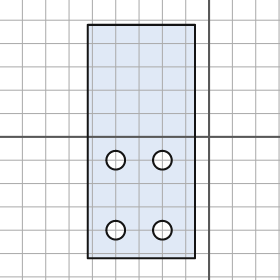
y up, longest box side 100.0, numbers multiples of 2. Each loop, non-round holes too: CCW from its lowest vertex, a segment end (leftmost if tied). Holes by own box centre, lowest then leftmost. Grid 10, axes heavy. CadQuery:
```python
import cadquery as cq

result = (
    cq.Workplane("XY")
    .moveTo(-52.0, -52.0)
    .lineTo(-6.0, -52.0)
    .lineTo(-6.0, 48.0)
    .lineTo(-52.0, 48.0)
    .close()
    .moveTo(-40.0, -40.0)
    .circle(4.0)
    .moveTo(-20.0, -40.0)
    .circle(4.0)
    .moveTo(-40.0, -10.0)
    .circle(4.0)
    .moveTo(-20.0, -10.0)
    .circle(4.0)
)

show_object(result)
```